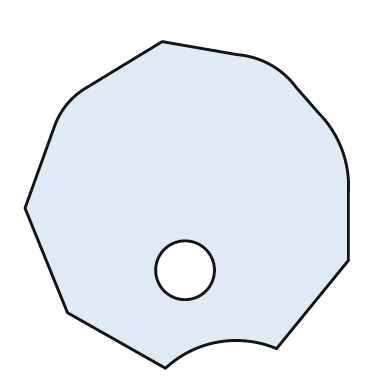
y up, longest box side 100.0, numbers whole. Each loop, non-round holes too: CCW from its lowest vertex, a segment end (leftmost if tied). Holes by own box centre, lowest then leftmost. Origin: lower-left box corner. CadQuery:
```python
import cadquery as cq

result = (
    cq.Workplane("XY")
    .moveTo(43.0, 0.0)
    .threePointArc((59.0, 8.0), (77.0, 6.0))
    .lineTo(99.0, 33.0)
    .lineTo(99.0, 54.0)
    .threePointArc((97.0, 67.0), (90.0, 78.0))
    .lineTo(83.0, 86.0)
    .threePointArc((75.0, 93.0), (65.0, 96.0))
    .lineTo(42.0, 100.0)
    .lineTo(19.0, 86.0)
    .threePointArc((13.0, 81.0), (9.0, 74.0))
    .lineTo(0.0, 49.0)
    .lineTo(13.0, 17.0)
    .close()
    .moveTo(49.0, 30.0)
    .circle(9.0)
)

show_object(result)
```